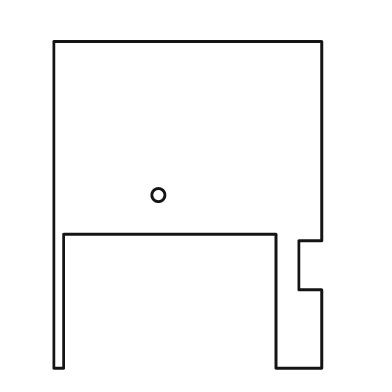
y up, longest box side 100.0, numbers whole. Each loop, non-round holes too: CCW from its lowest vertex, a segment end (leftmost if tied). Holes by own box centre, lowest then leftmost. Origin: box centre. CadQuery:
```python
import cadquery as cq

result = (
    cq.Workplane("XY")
    .moveTo(-41.0, -50.0)
    .lineTo(-38.0, -50.0)
    .lineTo(-38.0, -9.0)
    .lineTo(27.0, -9.0)
    .lineTo(27.0, -50.0)
    .lineTo(41.0, -50.0)
    .lineTo(41.0, -26.0)
    .lineTo(34.0, -26.0)
    .lineTo(34.0, -11.0)
    .lineTo(41.0, -11.0)
    .lineTo(41.0, 50.0)
    .lineTo(-41.0, 50.0)
    .close()
    .moveTo(-9.0, 3.0)
    .circle(2.0)
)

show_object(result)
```